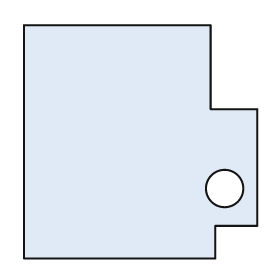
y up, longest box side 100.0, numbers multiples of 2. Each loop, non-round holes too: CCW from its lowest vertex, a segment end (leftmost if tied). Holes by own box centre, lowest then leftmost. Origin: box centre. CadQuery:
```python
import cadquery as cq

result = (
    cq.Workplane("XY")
    .moveTo(-50.0, -50.0)
    .lineTo(32.0, -50.0)
    .lineTo(32.0, -36.0)
    .lineTo(50.0, -36.0)
    .lineTo(50.0, 14.0)
    .lineTo(30.0, 14.0)
    .lineTo(30.0, 50.0)
    .lineTo(-50.0, 50.0)
    .close()
    .moveTo(36.0, -20.0)
    .circle(8.0)
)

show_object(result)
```